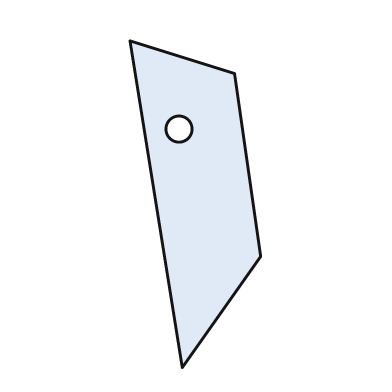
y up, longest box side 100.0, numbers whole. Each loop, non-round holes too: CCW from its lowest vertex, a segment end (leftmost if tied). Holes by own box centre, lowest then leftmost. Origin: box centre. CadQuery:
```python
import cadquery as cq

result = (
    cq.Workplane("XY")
    .moveTo(-4.0, -50.0)
    .lineTo(20.0, -16.0)
    .lineTo(12.0, 40.0)
    .lineTo(-20.0, 50.0)
    .close()
    .moveTo(-5.0, 23.0)
    .circle(4.0)
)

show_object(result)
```